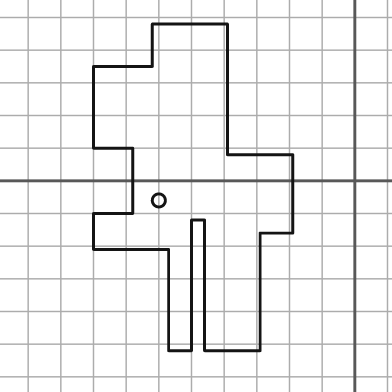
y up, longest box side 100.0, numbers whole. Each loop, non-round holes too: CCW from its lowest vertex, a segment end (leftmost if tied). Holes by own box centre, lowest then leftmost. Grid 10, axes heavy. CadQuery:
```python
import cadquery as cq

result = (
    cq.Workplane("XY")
    .moveTo(-57.0, -52.0)
    .lineTo(-50.0, -52.0)
    .lineTo(-50.0, -12.0)
    .lineTo(-46.0, -12.0)
    .lineTo(-46.0, -52.0)
    .lineTo(-29.0, -52.0)
    .lineTo(-29.0, -16.0)
    .lineTo(-19.0, -16.0)
    .lineTo(-19.0, 8.0)
    .lineTo(-39.0, 8.0)
    .lineTo(-39.0, 48.0)
    .lineTo(-62.0, 48.0)
    .lineTo(-62.0, 35.0)
    .lineTo(-80.0, 35.0)
    .lineTo(-80.0, 10.0)
    .lineTo(-68.0, 10.0)
    .lineTo(-68.0, -10.0)
    .lineTo(-80.0, -10.0)
    .lineTo(-80.0, -21.0)
    .lineTo(-57.0, -21.0)
    .close()
    .moveTo(-60.0, -6.0)
    .circle(2.0)
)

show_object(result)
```